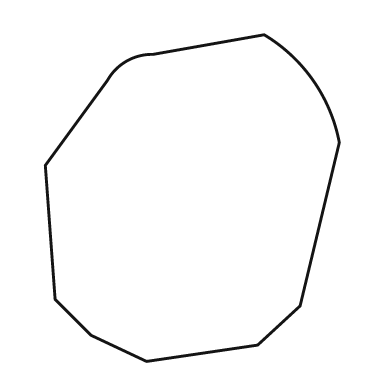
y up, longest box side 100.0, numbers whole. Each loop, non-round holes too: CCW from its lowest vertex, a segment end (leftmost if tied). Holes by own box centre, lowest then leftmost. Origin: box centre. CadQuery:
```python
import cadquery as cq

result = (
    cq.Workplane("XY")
    .moveTo(-14.0, -50.0)
    .lineTo(20.0, -45.0)
    .lineTo(33.0, -33.0)
    .lineTo(45.0, 17.0)
    .threePointArc((37.0, 36.0), (22.0, 50.0))
    .lineTo(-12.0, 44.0)
    .threePointArc((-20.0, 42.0), (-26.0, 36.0))
    .lineTo(-45.0, 10.0)
    .lineTo(-42.0, -31.0)
    .lineTo(-31.0, -42.0)
    .close()
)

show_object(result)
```